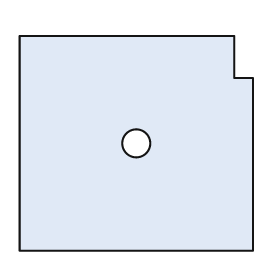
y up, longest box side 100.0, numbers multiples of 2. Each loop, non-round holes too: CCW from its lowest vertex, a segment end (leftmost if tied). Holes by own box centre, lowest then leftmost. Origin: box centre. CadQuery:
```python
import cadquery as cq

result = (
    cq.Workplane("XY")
    .moveTo(-50.0, -46.0)
    .lineTo(50.0, -46.0)
    .lineTo(50.0, 28.0)
    .lineTo(42.0, 28.0)
    .lineTo(42.0, 46.0)
    .lineTo(-50.0, 46.0)
    .close()
    .moveTo(0.0, 0.0)
    .circle(6.0)
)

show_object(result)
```